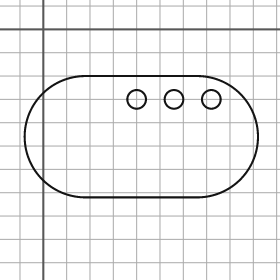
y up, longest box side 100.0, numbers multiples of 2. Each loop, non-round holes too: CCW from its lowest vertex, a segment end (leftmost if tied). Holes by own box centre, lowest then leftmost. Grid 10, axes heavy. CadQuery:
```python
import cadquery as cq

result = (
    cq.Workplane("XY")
    .moveTo(18.0, -72.0)
    .lineTo(66.0, -72.0)
    .threePointArc((92.0, -46.0), (66.0, -20.0))
    .lineTo(18.0, -20.0)
    .threePointArc((-8.0, -46.0), (18.0, -72.0))
    .close()
    .moveTo(40.0, -30.0)
    .circle(4.0)
    .moveTo(56.0, -30.0)
    .circle(4.0)
    .moveTo(72.0, -30.0)
    .circle(4.0)
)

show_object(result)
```